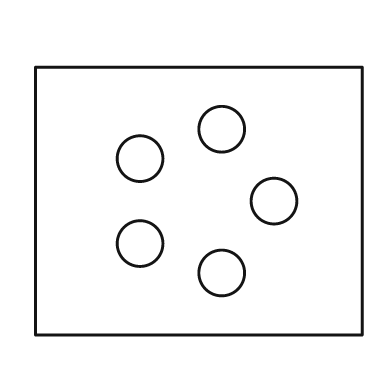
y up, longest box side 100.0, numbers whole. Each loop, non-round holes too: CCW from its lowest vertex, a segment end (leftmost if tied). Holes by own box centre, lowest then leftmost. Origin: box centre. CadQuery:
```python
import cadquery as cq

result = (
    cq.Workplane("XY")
    .moveTo(-50.0, -41.0)
    .lineTo(50.0, -41.0)
    .lineTo(50.0, 41.0)
    .lineTo(-50.0, 41.0)
    .close()
    .moveTo(7.0, -22.0)
    .circle(7.0)
    .moveTo(-18.0, -13.0)
    .circle(7.0)
    .moveTo(23.0, 0.0)
    .circle(7.0)
    .moveTo(-18.0, 13.0)
    .circle(7.0)
    .moveTo(7.0, 22.0)
    .circle(7.0)
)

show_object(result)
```